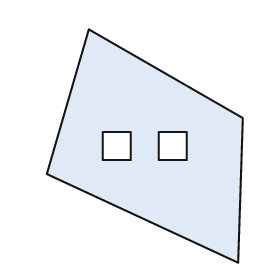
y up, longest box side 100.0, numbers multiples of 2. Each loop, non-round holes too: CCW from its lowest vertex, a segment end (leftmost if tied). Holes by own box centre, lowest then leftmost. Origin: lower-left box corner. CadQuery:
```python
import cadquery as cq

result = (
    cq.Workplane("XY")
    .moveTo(82.0, 0.0)
    .lineTo(84.0, 62.0)
    .lineTo(18.0, 100.0)
    .lineTo(0.0, 38.0)
    .close()
    .moveTo(24.0, 44.0)
    .lineTo(36.0, 44.0)
    .lineTo(36.0, 56.0)
    .lineTo(24.0, 56.0)
    .close()
    .moveTo(48.0, 44.0)
    .lineTo(60.0, 44.0)
    .lineTo(60.0, 56.0)
    .lineTo(48.0, 56.0)
    .close()
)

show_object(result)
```